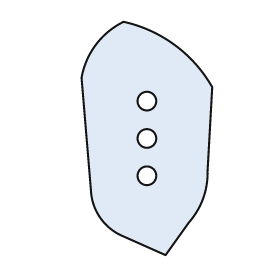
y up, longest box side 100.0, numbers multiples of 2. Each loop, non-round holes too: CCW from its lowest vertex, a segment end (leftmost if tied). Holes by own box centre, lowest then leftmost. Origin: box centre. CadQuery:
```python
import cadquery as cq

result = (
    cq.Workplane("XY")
    .moveTo(8.0, -50.0)
    .lineTo(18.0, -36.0)
    .threePointArc((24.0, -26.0), (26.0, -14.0))
    .lineTo(28.0, 22.0)
    .threePointArc((12.0, 40.0), (-10.0, 50.0))
    .threePointArc((-22.0, 40.0), (-28.0, 26.0))
    .lineTo(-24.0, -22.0)
    .threePointArc((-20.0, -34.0), (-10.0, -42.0))
    .close()
    .moveTo(0.0, -16.0)
    .circle(4.0)
    .moveTo(0.0, 0.0)
    .circle(4.0)
    .moveTo(0.0, 16.0)
    .circle(4.0)
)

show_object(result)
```